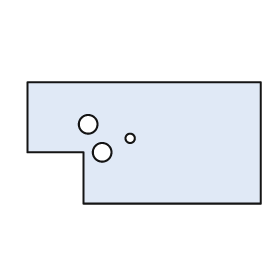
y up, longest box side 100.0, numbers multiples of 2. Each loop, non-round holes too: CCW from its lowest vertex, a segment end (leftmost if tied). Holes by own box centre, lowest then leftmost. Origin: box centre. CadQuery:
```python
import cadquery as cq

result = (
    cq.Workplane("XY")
    .moveTo(-26.0, -26.0)
    .lineTo(50.0, -26.0)
    .lineTo(50.0, 26.0)
    .lineTo(-50.0, 26.0)
    .lineTo(-50.0, -4.0)
    .lineTo(-26.0, -4.0)
    .close()
    .moveTo(-18.0, -4.0)
    .circle(4.0)
    .moveTo(-6.0, 2.0)
    .circle(2.0)
    .moveTo(-24.0, 8.0)
    .circle(4.0)
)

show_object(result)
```